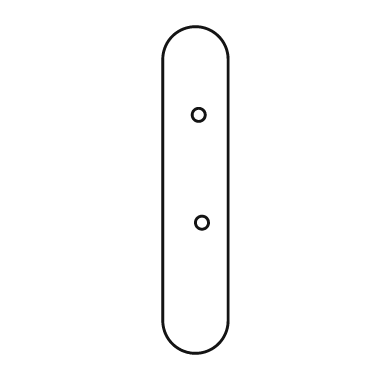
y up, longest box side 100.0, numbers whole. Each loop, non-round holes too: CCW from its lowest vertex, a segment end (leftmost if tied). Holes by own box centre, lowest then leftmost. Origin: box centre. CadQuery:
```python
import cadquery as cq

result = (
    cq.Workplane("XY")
    .moveTo(-10.0, -40.0)
    .threePointArc((0.0, -50.0), (10.0, -40.0))
    .lineTo(10.0, 40.0)
    .threePointArc((0.0, 50.0), (-10.0, 40.0))
    .close()
    .moveTo(2.0, -10.0)
    .circle(2.0)
    .moveTo(1.0, 23.0)
    .circle(2.0)
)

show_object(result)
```